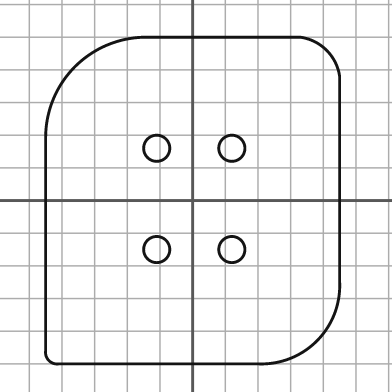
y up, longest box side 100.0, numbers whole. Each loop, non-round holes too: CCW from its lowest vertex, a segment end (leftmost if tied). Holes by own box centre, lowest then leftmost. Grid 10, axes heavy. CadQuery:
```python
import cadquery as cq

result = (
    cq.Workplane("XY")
    .moveTo(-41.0, -50.0)
    .lineTo(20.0, -50.0)
    .threePointArc((38.0, -43.0), (45.0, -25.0))
    .lineTo(45.0, 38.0)
    .threePointArc((41.0, 46.0), (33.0, 50.0))
    .lineTo(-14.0, 50.0)
    .threePointArc((-36.0, 41.0), (-45.0, 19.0))
    .lineTo(-45.0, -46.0)
    .threePointArc((-44.0, -49.0), (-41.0, -50.0))
    .close()
    .moveTo(-11.0, -15.0)
    .circle(4.0)
    .moveTo(12.0, -15.0)
    .circle(4.0)
    .moveTo(-11.0, 16.0)
    .circle(4.0)
    .moveTo(12.0, 16.0)
    .circle(4.0)
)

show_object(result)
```